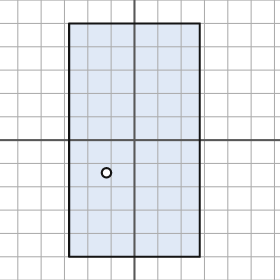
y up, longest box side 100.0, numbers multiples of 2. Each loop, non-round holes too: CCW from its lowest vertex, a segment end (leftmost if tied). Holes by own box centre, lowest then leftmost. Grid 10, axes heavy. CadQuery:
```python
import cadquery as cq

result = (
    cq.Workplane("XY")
    .moveTo(-28.0, -50.0)
    .lineTo(28.0, -50.0)
    .lineTo(28.0, 50.0)
    .lineTo(-28.0, 50.0)
    .close()
    .moveTo(-12.0, -14.0)
    .circle(2.0)
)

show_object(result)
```